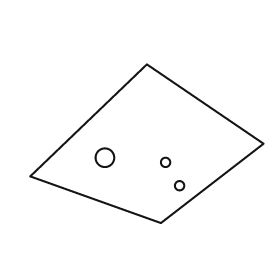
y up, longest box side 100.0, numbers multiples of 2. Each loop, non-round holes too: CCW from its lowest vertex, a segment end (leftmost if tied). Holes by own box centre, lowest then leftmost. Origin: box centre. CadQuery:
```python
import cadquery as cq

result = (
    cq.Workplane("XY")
    .moveTo(6.0, -34.0)
    .lineTo(50.0, 0.0)
    .lineTo(0.0, 34.0)
    .lineTo(-50.0, -14.0)
    .close()
    .moveTo(14.0, -18.0)
    .circle(2.0)
    .moveTo(8.0, -8.0)
    .circle(2.0)
    .moveTo(-18.0, -6.0)
    .circle(4.0)
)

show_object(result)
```